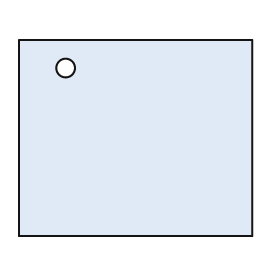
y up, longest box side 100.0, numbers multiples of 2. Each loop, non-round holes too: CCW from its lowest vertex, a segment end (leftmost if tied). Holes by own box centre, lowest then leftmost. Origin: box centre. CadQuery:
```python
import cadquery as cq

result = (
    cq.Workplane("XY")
    .moveTo(-50.0, -42.0)
    .lineTo(50.0, -42.0)
    .lineTo(50.0, 42.0)
    .lineTo(-50.0, 42.0)
    .close()
    .moveTo(-30.0, 30.0)
    .circle(4.0)
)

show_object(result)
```